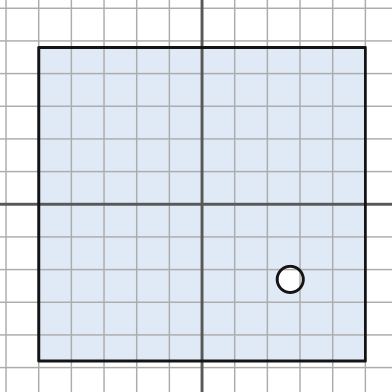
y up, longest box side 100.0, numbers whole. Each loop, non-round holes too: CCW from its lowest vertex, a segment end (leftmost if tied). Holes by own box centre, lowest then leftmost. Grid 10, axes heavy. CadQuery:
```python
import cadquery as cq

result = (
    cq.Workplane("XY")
    .moveTo(-50.0, -48.0)
    .lineTo(50.0, -48.0)
    .lineTo(50.0, 48.0)
    .lineTo(-50.0, 48.0)
    .close()
    .moveTo(27.0, -23.0)
    .circle(4.0)
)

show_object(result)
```